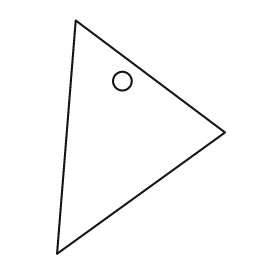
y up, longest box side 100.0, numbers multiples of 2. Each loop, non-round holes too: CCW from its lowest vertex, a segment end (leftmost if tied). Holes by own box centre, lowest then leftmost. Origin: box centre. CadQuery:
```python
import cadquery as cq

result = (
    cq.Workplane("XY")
    .moveTo(-36.0, -50.0)
    .lineTo(36.0, 2.0)
    .lineTo(-28.0, 50.0)
    .close()
    .moveTo(-8.0, 24.0)
    .circle(4.0)
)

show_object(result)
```